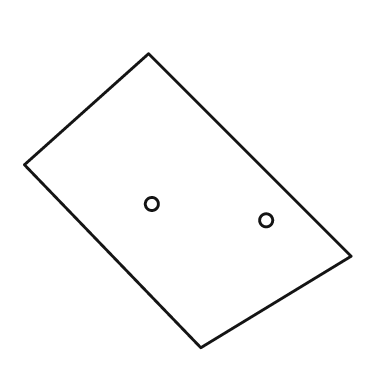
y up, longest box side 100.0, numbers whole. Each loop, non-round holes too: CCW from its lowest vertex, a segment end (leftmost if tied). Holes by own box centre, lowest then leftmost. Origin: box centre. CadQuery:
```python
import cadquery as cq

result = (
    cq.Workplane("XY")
    .moveTo(4.0, -45.0)
    .lineTo(50.0, -17.0)
    .lineTo(-12.0, 45.0)
    .lineTo(-50.0, 11.0)
    .close()
    .moveTo(24.0, -6.0)
    .circle(2.0)
    .moveTo(-11.0, -1.0)
    .circle(2.0)
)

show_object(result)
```